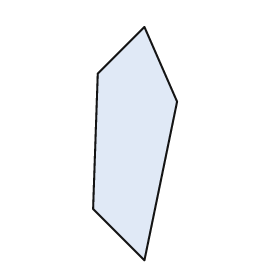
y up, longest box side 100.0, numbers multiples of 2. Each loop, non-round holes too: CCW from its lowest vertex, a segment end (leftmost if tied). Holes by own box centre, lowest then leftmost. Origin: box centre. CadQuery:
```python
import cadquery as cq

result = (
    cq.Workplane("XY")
    .moveTo(4.0, -50.0)
    .lineTo(18.0, 18.0)
    .lineTo(4.0, 50.0)
    .lineTo(-16.0, 30.0)
    .lineTo(-18.0, -28.0)
    .close()
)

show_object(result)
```